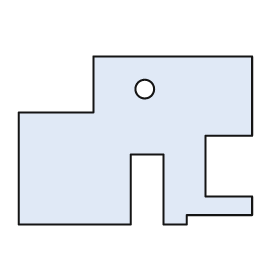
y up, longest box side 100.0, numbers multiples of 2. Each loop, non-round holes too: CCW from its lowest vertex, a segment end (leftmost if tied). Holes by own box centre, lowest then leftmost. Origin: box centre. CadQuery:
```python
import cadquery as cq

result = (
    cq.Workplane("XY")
    .moveTo(-50.0, -36.0)
    .lineTo(-2.0, -36.0)
    .lineTo(-2.0, -6.0)
    .lineTo(12.0, -6.0)
    .lineTo(12.0, -36.0)
    .lineTo(22.0, -36.0)
    .lineTo(22.0, -32.0)
    .lineTo(50.0, -32.0)
    .lineTo(50.0, -24.0)
    .lineTo(30.0, -24.0)
    .lineTo(30.0, 2.0)
    .lineTo(50.0, 2.0)
    .lineTo(50.0, 36.0)
    .lineTo(-18.0, 36.0)
    .lineTo(-18.0, 12.0)
    .lineTo(-50.0, 12.0)
    .close()
    .moveTo(4.0, 22.0)
    .circle(4.0)
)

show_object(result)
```